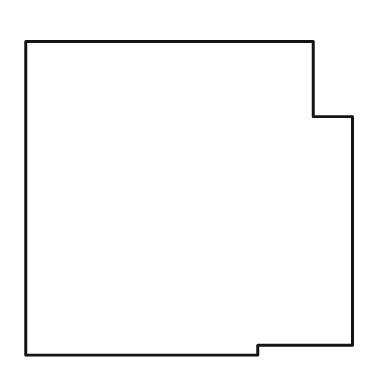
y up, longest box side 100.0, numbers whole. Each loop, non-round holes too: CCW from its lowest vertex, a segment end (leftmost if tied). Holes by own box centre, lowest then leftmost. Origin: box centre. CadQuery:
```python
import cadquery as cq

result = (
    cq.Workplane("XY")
    .moveTo(-50.0, -48.0)
    .lineTo(21.0, -48.0)
    .lineTo(21.0, -45.0)
    .lineTo(50.0, -45.0)
    .lineTo(50.0, 25.0)
    .lineTo(38.0, 25.0)
    .lineTo(38.0, 48.0)
    .lineTo(-50.0, 48.0)
    .close()
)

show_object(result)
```